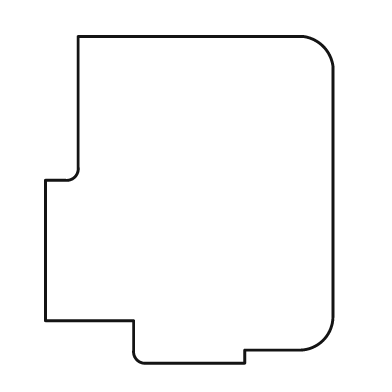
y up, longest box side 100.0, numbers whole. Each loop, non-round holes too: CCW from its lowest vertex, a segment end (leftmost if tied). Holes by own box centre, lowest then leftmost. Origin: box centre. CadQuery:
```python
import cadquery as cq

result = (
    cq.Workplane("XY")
    .moveTo(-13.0, -50.0)
    .lineTo(17.0, -50.0)
    .lineTo(17.0, -46.0)
    .lineTo(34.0, -46.0)
    .threePointArc((41.0, -43.0), (44.0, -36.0))
    .lineTo(44.0, 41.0)
    .threePointArc((41.0, 47.0), (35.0, 50.0))
    .lineTo(-34.0, 50.0)
    .lineTo(-34.0, 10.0)
    .threePointArc((-35.0, 7.0), (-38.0, 6.0))
    .lineTo(-44.0, 6.0)
    .lineTo(-44.0, -37.0)
    .lineTo(-17.0, -37.0)
    .lineTo(-17.0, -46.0)
    .threePointArc((-16.0, -49.0), (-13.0, -50.0))
    .close()
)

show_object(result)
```